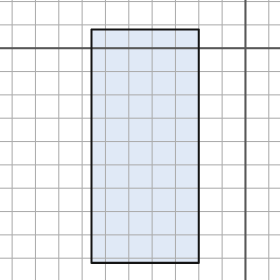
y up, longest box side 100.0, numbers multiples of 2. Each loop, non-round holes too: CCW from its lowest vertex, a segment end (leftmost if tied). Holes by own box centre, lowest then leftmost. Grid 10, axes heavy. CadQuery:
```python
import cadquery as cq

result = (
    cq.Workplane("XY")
    .moveTo(-66.0, -92.0)
    .lineTo(-20.0, -92.0)
    .lineTo(-20.0, 8.0)
    .lineTo(-66.0, 8.0)
    .close()
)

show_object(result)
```